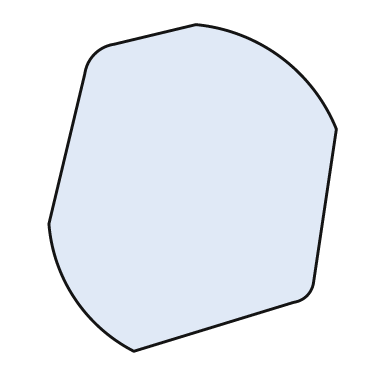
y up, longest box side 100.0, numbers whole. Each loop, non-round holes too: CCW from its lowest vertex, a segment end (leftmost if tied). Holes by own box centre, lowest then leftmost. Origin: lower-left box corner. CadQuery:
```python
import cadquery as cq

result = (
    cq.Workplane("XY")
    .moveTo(26.0, 0.0)
    .lineTo(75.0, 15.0)
    .threePointArc((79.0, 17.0), (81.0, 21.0))
    .lineTo(88.0, 68.0)
    .threePointArc((71.0, 90.0), (45.0, 100.0))
    .lineTo(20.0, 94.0)
    .threePointArc((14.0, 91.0), (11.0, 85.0))
    .lineTo(0.0, 39.0)
    .threePointArc((8.0, 16.0), (26.0, 0.0))
    .close()
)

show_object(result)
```